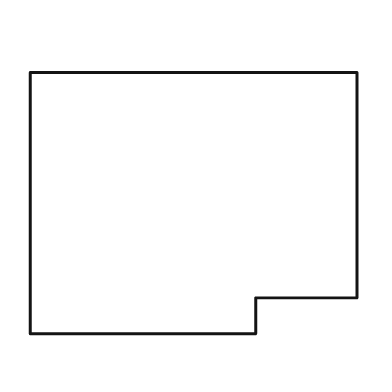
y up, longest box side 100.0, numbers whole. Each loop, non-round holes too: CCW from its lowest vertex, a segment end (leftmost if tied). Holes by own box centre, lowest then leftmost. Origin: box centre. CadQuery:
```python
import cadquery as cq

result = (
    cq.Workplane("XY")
    .moveTo(-50.0, -40.0)
    .lineTo(19.0, -40.0)
    .lineTo(19.0, -29.0)
    .lineTo(50.0, -29.0)
    .lineTo(50.0, 40.0)
    .lineTo(-50.0, 40.0)
    .close()
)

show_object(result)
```